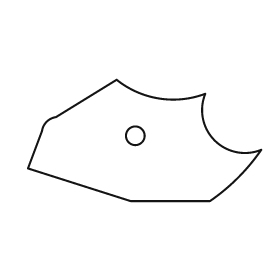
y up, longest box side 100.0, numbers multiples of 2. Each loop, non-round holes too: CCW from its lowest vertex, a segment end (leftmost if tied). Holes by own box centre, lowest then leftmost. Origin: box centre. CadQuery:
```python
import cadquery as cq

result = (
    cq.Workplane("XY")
    .moveTo(-6.0, -26.0)
    .lineTo(28.0, -26.0)
    .threePointArc((40.0, -16.0), (50.0, -4.0))
    .threePointArc((30.0, 0.0), (26.0, 20.0))
    .threePointArc((6.0, 18.0), (-12.0, 26.0))
    .lineTo(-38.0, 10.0)
    .threePointArc((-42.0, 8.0), (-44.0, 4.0))
    .lineTo(-50.0, -12.0)
    .close()
    .moveTo(-4.0, 2.0)
    .circle(4.0)
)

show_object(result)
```